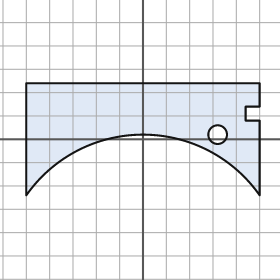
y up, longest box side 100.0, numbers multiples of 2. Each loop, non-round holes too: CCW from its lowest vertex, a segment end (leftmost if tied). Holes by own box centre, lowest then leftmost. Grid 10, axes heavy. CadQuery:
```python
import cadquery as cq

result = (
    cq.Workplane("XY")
    .moveTo(-50.0, -24.0)
    .threePointArc((0.0, 2.0), (50.0, -24.0))
    .lineTo(50.0, 8.0)
    .lineTo(44.0, 8.0)
    .lineTo(44.0, 14.0)
    .lineTo(50.0, 14.0)
    .lineTo(50.0, 24.0)
    .lineTo(-50.0, 24.0)
    .close()
    .moveTo(32.0, 2.0)
    .circle(4.0)
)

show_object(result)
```